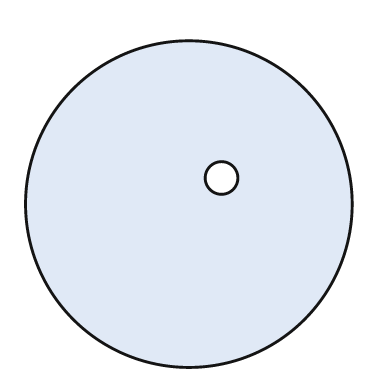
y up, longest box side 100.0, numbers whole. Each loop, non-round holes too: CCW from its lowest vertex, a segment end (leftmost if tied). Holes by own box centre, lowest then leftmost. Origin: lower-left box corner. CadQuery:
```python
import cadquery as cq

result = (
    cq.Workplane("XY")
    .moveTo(50.0, 50.0)
    .circle(50.0)
    .moveTo(60.0, 58.0)
    .circle(5.0)
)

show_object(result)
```